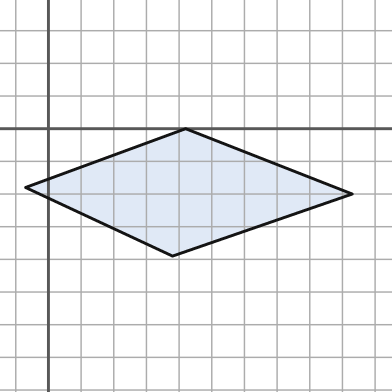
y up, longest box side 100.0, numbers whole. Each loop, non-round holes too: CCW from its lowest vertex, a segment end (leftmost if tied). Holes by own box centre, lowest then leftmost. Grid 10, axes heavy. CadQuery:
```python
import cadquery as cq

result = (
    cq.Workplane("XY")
    .moveTo(38.0, -39.0)
    .lineTo(93.0, -20.0)
    .lineTo(42.0, 0.0)
    .lineTo(-7.0, -18.0)
    .close()
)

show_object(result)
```